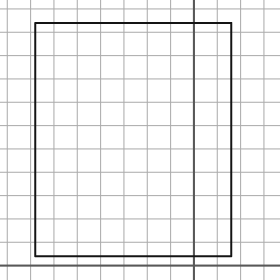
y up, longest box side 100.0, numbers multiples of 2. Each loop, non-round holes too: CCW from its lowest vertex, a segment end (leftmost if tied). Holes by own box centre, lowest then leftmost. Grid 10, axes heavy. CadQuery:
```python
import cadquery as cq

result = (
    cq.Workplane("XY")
    .moveTo(-68.0, 4.0)
    .lineTo(16.0, 4.0)
    .lineTo(16.0, 104.0)
    .lineTo(-68.0, 104.0)
    .close()
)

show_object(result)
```